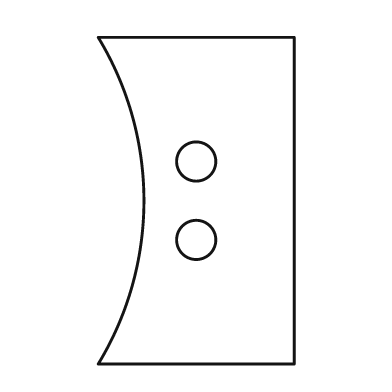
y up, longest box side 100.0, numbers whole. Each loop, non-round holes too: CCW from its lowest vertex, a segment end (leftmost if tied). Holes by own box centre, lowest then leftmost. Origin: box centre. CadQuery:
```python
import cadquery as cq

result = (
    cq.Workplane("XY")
    .moveTo(-30.0, -50.0)
    .lineTo(30.0, -50.0)
    .lineTo(30.0, 50.0)
    .lineTo(-30.0, 50.0)
    .threePointArc((-16.0, 0.0), (-30.0, -50.0))
    .close()
    .moveTo(0.0, -12.0)
    .circle(6.0)
    .moveTo(0.0, 12.0)
    .circle(6.0)
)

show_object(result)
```